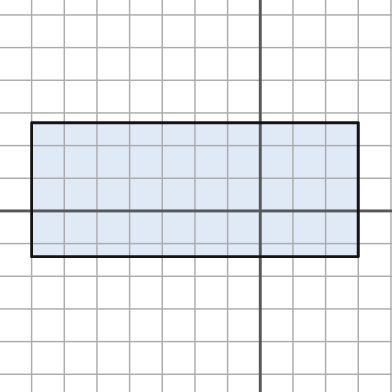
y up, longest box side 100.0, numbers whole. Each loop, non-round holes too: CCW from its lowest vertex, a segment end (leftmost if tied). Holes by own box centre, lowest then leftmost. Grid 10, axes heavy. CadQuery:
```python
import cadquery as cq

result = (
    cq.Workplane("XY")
    .moveTo(-70.0, -14.0)
    .lineTo(30.0, -14.0)
    .lineTo(30.0, 27.0)
    .lineTo(-70.0, 27.0)
    .close()
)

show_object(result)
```